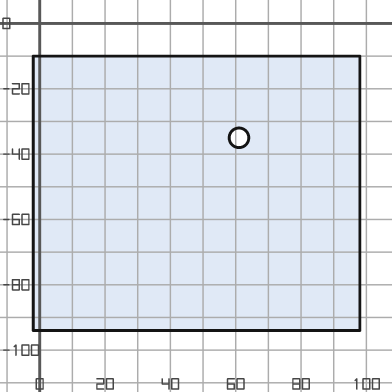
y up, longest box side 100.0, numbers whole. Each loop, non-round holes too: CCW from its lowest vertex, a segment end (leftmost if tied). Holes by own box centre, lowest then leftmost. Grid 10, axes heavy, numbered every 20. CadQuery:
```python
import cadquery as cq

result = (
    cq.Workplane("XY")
    .moveTo(-2.0, -94.0)
    .lineTo(98.0, -94.0)
    .lineTo(98.0, -10.0)
    .lineTo(-2.0, -10.0)
    .close()
    .moveTo(61.0, -35.0)
    .circle(3.0)
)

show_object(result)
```